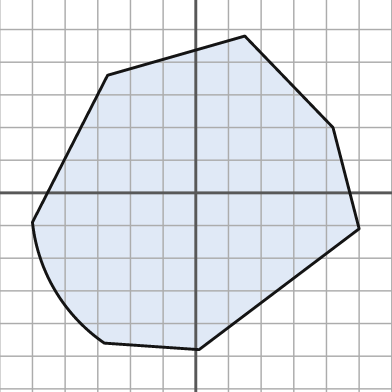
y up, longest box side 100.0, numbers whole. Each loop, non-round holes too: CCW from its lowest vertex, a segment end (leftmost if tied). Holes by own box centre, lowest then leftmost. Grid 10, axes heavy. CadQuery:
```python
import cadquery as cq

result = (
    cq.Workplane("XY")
    .moveTo(1.0, -48.0)
    .lineTo(50.0, -11.0)
    .lineTo(42.0, 20.0)
    .lineTo(15.0, 48.0)
    .lineTo(-27.0, 36.0)
    .lineTo(-50.0, -9.0)
    .threePointArc((-43.0, -30.0), (-28.0, -46.0))
    .close()
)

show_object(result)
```